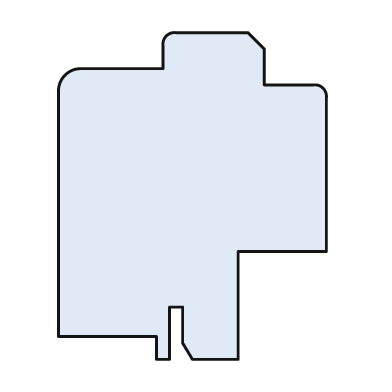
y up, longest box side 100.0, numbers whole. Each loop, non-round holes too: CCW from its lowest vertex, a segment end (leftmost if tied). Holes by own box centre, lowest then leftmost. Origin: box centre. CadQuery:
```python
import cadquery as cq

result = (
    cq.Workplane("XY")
    .moveTo(-11.0, -50.0)
    .lineTo(-7.0, -50.0)
    .lineTo(-7.0, -34.0)
    .lineTo(-3.0, -34.0)
    .lineTo(-3.0, -45.0)
    .lineTo(0.0, -50.0)
    .lineTo(14.0, -50.0)
    .lineTo(14.0, -17.0)
    .lineTo(41.0, -17.0)
    .lineTo(41.0, 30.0)
    .threePointArc((40.0, 33.0), (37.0, 34.0))
    .lineTo(22.0, 34.0)
    .lineTo(22.0, 45.0)
    .lineTo(17.0, 50.0)
    .lineTo(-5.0, 50.0)
    .threePointArc((-8.0, 49.0), (-9.0, 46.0))
    .lineTo(-9.0, 39.0)
    .lineTo(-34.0, 39.0)
    .threePointArc((-39.0, 37.0), (-41.0, 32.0))
    .lineTo(-41.0, -43.0)
    .lineTo(-11.0, -43.0)
    .close()
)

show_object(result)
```